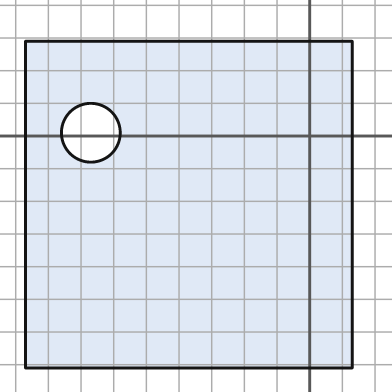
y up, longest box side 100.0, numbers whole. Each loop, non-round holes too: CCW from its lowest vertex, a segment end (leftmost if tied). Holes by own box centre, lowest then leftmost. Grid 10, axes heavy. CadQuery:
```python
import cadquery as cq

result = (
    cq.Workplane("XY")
    .moveTo(-87.0, -71.0)
    .lineTo(13.0, -71.0)
    .lineTo(13.0, 29.0)
    .lineTo(-87.0, 29.0)
    .close()
    .moveTo(-67.0, 1.0)
    .circle(9.0)
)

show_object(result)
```